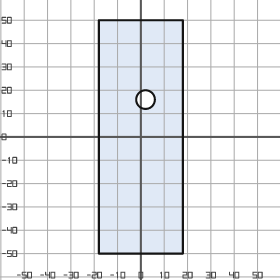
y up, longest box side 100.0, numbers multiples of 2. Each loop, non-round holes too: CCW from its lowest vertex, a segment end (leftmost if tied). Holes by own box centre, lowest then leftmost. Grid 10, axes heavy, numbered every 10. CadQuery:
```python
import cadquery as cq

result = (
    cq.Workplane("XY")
    .moveTo(-18.0, -50.0)
    .lineTo(18.0, -50.0)
    .lineTo(18.0, 50.0)
    .lineTo(-18.0, 50.0)
    .close()
    .moveTo(2.0, 16.0)
    .circle(4.0)
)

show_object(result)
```